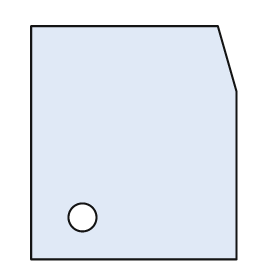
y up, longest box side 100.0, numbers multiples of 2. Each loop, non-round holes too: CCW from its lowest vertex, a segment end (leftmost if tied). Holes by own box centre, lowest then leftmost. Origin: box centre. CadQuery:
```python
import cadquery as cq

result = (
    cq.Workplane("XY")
    .moveTo(-44.0, -50.0)
    .lineTo(44.0, -50.0)
    .lineTo(44.0, 22.0)
    .lineTo(36.0, 50.0)
    .lineTo(-44.0, 50.0)
    .close()
    .moveTo(-22.0, -32.0)
    .circle(6.0)
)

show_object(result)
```